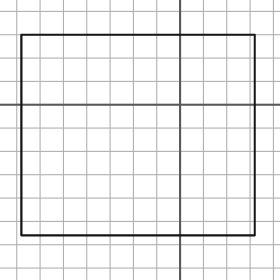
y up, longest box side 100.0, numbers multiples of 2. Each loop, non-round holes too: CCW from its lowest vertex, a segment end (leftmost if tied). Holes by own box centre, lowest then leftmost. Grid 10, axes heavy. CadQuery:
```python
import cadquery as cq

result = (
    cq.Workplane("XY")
    .moveTo(-68.0, -56.0)
    .lineTo(32.0, -56.0)
    .lineTo(32.0, 30.0)
    .lineTo(-68.0, 30.0)
    .close()
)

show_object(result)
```